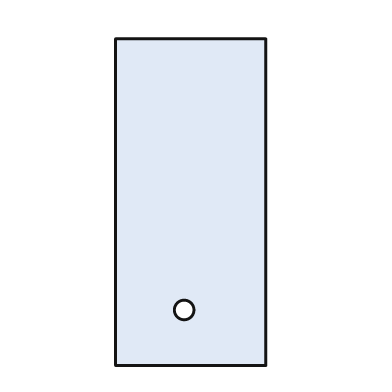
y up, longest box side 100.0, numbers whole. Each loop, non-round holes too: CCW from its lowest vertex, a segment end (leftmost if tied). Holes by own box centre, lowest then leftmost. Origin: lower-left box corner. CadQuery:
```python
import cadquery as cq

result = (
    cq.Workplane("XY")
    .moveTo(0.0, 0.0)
    .lineTo(46.0, 0.0)
    .lineTo(46.0, 100.0)
    .lineTo(0.0, 100.0)
    .close()
    .moveTo(21.0, 17.0)
    .circle(3.0)
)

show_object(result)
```